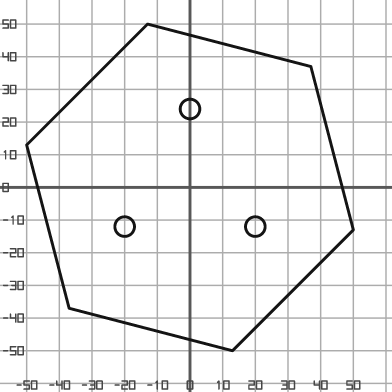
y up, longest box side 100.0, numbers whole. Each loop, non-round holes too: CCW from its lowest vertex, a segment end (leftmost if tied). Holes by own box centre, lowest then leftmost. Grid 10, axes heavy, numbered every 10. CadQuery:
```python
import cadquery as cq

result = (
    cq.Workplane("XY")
    .moveTo(13.0, -50.0)
    .lineTo(50.0, -13.0)
    .lineTo(37.0, 37.0)
    .lineTo(-13.0, 50.0)
    .lineTo(-50.0, 13.0)
    .lineTo(-37.0, -37.0)
    .close()
    .moveTo(-20.0, -12.0)
    .circle(3.0)
    .moveTo(20.0, -12.0)
    .circle(3.0)
    .moveTo(0.0, 24.0)
    .circle(3.0)
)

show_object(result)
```